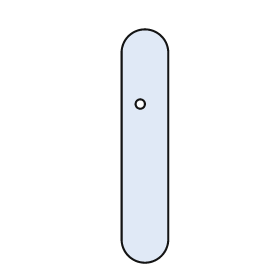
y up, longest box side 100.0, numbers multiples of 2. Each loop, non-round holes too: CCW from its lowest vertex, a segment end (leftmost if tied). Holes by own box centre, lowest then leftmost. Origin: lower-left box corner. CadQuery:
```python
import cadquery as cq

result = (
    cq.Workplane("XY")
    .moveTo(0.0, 10.0)
    .threePointArc((10.0, 0.0), (20.0, 10.0))
    .lineTo(20.0, 90.0)
    .threePointArc((10.0, 100.0), (0.0, 90.0))
    .close()
    .moveTo(8.0, 68.0)
    .circle(2.0)
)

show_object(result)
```